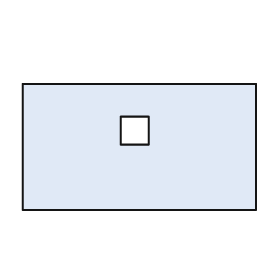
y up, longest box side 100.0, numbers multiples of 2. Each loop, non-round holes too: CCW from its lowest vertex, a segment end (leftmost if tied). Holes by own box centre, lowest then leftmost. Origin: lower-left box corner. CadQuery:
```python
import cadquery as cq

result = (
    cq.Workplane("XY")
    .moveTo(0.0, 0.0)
    .lineTo(100.0, 0.0)
    .lineTo(100.0, 54.0)
    .lineTo(0.0, 54.0)
    .close()
    .moveTo(42.0, 28.0)
    .lineTo(54.0, 28.0)
    .lineTo(54.0, 40.0)
    .lineTo(42.0, 40.0)
    .close()
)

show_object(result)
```